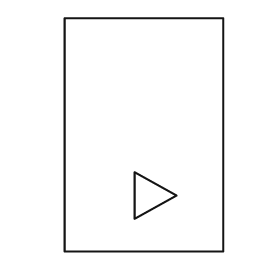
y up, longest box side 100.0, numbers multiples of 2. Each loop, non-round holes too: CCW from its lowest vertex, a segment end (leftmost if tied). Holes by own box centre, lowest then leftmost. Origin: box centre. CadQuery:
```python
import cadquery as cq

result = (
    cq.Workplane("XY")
    .moveTo(-34.0, -50.0)
    .lineTo(34.0, -50.0)
    .lineTo(34.0, 50.0)
    .lineTo(-34.0, 50.0)
    .close()
    .moveTo(-4.0, -36.0)
    .lineTo(14.0, -26.0)
    .lineTo(-4.0, -16.0)
    .close()
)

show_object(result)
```